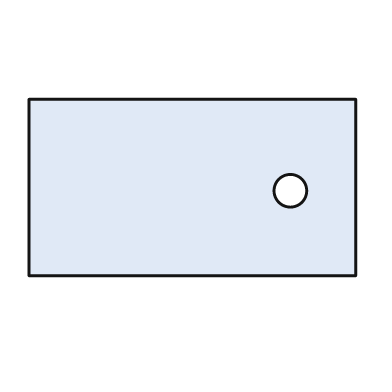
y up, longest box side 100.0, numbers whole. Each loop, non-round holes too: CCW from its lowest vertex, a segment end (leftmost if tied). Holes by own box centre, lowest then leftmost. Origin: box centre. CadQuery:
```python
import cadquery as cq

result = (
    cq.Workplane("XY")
    .moveTo(-50.0, -27.0)
    .lineTo(50.0, -27.0)
    .lineTo(50.0, 27.0)
    .lineTo(-50.0, 27.0)
    .close()
    .moveTo(30.0, -1.0)
    .circle(5.0)
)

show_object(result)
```